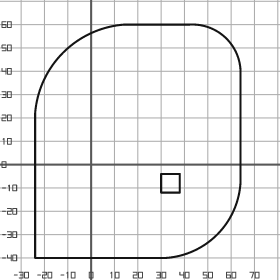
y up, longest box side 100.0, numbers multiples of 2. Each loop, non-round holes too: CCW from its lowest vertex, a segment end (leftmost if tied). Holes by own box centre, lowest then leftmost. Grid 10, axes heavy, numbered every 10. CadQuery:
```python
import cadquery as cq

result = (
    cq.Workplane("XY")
    .moveTo(-24.0, -40.0)
    .lineTo(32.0, -40.0)
    .threePointArc((54.0, -30.0), (64.0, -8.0))
    .lineTo(64.0, 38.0)
    .threePointArc((58.0, 54.0), (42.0, 60.0))
    .lineTo(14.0, 60.0)
    .threePointArc((-12.0, 48.0), (-24.0, 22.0))
    .close()
    .moveTo(30.0, -12.0)
    .lineTo(38.0, -12.0)
    .lineTo(38.0, -4.0)
    .lineTo(30.0, -4.0)
    .close()
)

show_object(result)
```